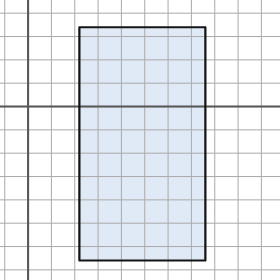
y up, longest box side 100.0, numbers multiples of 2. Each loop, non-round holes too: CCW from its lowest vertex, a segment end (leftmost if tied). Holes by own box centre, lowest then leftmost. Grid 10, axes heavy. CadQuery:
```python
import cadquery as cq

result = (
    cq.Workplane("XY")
    .moveTo(22.0, -66.0)
    .lineTo(76.0, -66.0)
    .lineTo(76.0, 34.0)
    .lineTo(22.0, 34.0)
    .close()
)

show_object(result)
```